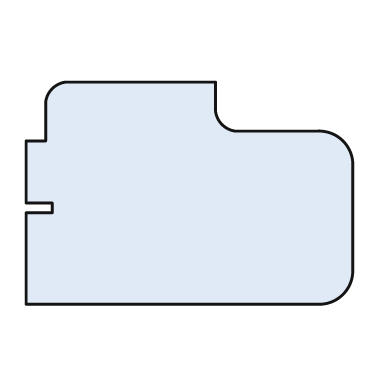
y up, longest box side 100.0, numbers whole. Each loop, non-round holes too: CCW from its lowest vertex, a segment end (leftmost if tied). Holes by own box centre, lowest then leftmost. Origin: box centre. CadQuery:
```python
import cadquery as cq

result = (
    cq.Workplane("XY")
    .moveTo(-50.0, -34.0)
    .lineTo(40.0, -34.0)
    .threePointArc((47.0, -31.0), (50.0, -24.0))
    .lineTo(50.0, 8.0)
    .threePointArc((47.0, 16.0), (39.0, 19.0))
    .lineTo(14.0, 19.0)
    .threePointArc((10.0, 21.0), (8.0, 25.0))
    .lineTo(8.0, 34.0)
    .lineTo(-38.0, 34.0)
    .threePointArc((-42.0, 32.0), (-44.0, 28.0))
    .lineTo(-44.0, 16.0)
    .lineTo(-50.0, 16.0)
    .lineTo(-50.0, -3.0)
    .lineTo(-42.0, -3.0)
    .lineTo(-42.0, -6.0)
    .lineTo(-50.0, -6.0)
    .close()
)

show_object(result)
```